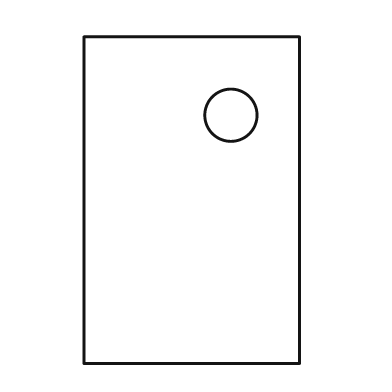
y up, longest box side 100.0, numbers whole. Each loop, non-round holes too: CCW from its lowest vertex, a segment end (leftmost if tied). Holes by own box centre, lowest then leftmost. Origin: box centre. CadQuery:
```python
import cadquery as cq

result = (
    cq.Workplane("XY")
    .moveTo(-33.0, -50.0)
    .lineTo(33.0, -50.0)
    .lineTo(33.0, 50.0)
    .lineTo(-33.0, 50.0)
    .close()
    .moveTo(12.0, 26.0)
    .circle(8.0)
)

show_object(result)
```